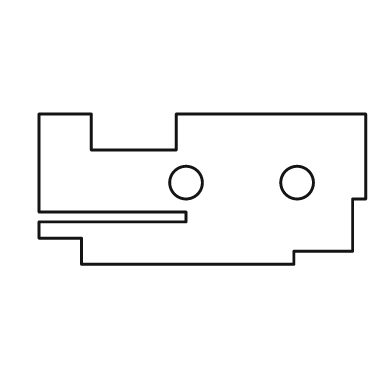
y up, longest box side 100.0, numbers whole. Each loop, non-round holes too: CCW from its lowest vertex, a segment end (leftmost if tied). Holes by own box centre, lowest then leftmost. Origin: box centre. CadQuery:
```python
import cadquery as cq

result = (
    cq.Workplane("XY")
    .moveTo(-37.0, -23.0)
    .lineTo(28.0, -23.0)
    .lineTo(28.0, -19.0)
    .lineTo(46.0, -19.0)
    .lineTo(46.0, -3.0)
    .lineTo(50.0, -3.0)
    .lineTo(50.0, 23.0)
    .lineTo(-8.0, 23.0)
    .lineTo(-8.0, 12.0)
    .lineTo(-34.0, 12.0)
    .lineTo(-34.0, 23.0)
    .lineTo(-50.0, 23.0)
    .lineTo(-50.0, -7.0)
    .lineTo(-5.0, -7.0)
    .lineTo(-5.0, -10.0)
    .lineTo(-50.0, -10.0)
    .lineTo(-50.0, -15.0)
    .lineTo(-37.0, -15.0)
    .close()
    .moveTo(-5.0, 2.0)
    .circle(5.0)
    .moveTo(29.0, 2.0)
    .circle(5.0)
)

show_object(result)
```